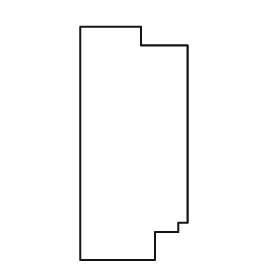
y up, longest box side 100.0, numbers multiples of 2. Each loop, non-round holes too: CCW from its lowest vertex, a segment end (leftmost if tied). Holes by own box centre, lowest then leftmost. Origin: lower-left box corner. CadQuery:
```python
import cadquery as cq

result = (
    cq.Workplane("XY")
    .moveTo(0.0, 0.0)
    .lineTo(32.0, 0.0)
    .lineTo(32.0, 12.0)
    .lineTo(42.0, 12.0)
    .lineTo(42.0, 16.0)
    .lineTo(46.0, 16.0)
    .lineTo(46.0, 92.0)
    .lineTo(26.0, 92.0)
    .lineTo(26.0, 100.0)
    .lineTo(0.0, 100.0)
    .close()
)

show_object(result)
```